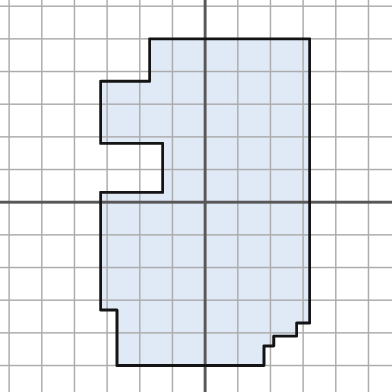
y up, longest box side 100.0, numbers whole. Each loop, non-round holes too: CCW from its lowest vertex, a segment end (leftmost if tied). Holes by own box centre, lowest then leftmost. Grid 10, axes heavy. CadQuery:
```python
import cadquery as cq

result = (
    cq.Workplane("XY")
    .moveTo(-27.0, -50.0)
    .lineTo(18.0, -50.0)
    .lineTo(18.0, -44.0)
    .lineTo(21.0, -44.0)
    .lineTo(21.0, -41.0)
    .lineTo(28.0, -41.0)
    .lineTo(28.0, -37.0)
    .lineTo(32.0, -37.0)
    .lineTo(32.0, 50.0)
    .lineTo(-17.0, 50.0)
    .lineTo(-17.0, 37.0)
    .lineTo(-32.0, 37.0)
    .lineTo(-32.0, 18.0)
    .lineTo(-13.0, 18.0)
    .lineTo(-13.0, 3.0)
    .lineTo(-32.0, 3.0)
    .lineTo(-32.0, -33.0)
    .lineTo(-27.0, -33.0)
    .close()
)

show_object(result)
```